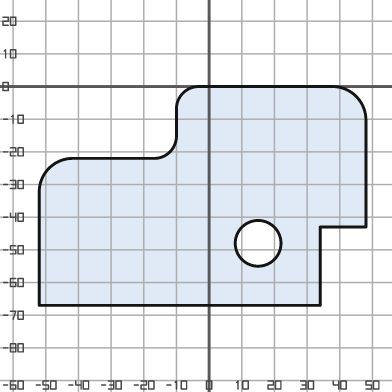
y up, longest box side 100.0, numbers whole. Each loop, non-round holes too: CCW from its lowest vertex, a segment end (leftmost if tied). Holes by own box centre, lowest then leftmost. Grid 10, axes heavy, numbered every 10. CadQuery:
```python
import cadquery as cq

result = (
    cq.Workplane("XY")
    .moveTo(-52.0, -67.0)
    .lineTo(34.0, -67.0)
    .lineTo(34.0, -43.0)
    .lineTo(48.0, -43.0)
    .lineTo(48.0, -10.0)
    .threePointArc((45.0, -3.0), (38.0, 0.0))
    .lineTo(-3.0, 0.0)
    .threePointArc((-8.0, -2.0), (-10.0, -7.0))
    .lineTo(-10.0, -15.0)
    .threePointArc((-12.0, -20.0), (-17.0, -22.0))
    .lineTo(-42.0, -22.0)
    .threePointArc((-49.0, -25.0), (-52.0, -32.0))
    .close()
    .moveTo(15.0, -48.0)
    .circle(7.0)
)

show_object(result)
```